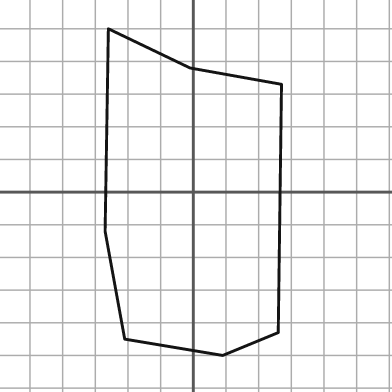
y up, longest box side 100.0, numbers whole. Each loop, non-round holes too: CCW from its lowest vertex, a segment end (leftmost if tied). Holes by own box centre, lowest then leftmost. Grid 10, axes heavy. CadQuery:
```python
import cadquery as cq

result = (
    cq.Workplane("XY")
    .moveTo(9.0, -50.0)
    .lineTo(26.0, -43.0)
    .lineTo(27.0, 33.0)
    .lineTo(-1.0, 38.0)
    .lineTo(-26.0, 50.0)
    .lineTo(-27.0, -12.0)
    .lineTo(-21.0, -45.0)
    .close()
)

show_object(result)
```